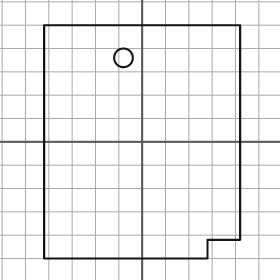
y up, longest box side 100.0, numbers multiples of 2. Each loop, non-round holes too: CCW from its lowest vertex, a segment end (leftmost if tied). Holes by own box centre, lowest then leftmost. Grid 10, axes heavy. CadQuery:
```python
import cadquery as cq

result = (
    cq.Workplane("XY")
    .moveTo(-42.0, -50.0)
    .lineTo(28.0, -50.0)
    .lineTo(28.0, -42.0)
    .lineTo(42.0, -42.0)
    .lineTo(42.0, 50.0)
    .lineTo(-42.0, 50.0)
    .close()
    .moveTo(-8.0, 36.0)
    .circle(4.0)
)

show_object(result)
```